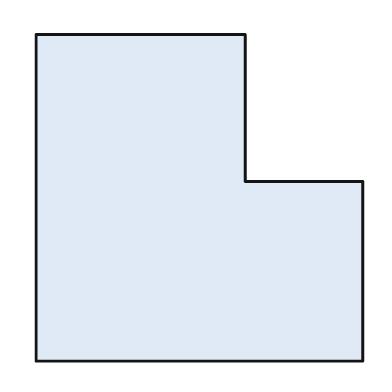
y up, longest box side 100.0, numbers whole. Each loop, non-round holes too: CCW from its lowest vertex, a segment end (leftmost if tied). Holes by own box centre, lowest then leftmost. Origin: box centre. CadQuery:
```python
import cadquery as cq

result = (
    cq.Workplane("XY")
    .moveTo(-50.0, -50.0)
    .lineTo(50.0, -50.0)
    .lineTo(50.0, 5.0)
    .lineTo(14.0, 5.0)
    .lineTo(14.0, 50.0)
    .lineTo(-50.0, 50.0)
    .close()
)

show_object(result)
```